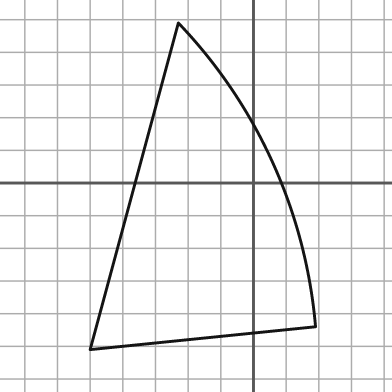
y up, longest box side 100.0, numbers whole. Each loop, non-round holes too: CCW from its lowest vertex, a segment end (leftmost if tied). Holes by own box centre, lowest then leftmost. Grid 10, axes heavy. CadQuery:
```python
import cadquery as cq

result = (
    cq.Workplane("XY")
    .moveTo(-50.0, -51.0)
    .lineTo(19.0, -44.0)
    .threePointArc((6.0, 6.0), (-23.0, 49.0))
    .close()
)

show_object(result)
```